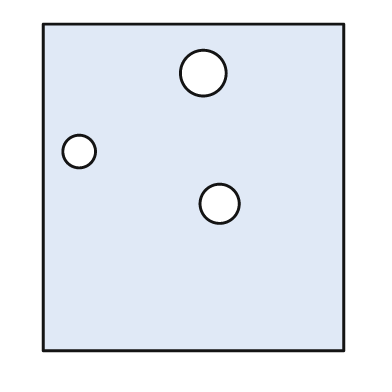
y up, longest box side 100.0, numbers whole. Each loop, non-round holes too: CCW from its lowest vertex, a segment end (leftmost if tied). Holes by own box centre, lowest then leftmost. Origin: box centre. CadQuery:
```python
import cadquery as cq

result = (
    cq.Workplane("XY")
    .moveTo(-46.0, -50.0)
    .lineTo(46.0, -50.0)
    .lineTo(46.0, 50.0)
    .lineTo(-46.0, 50.0)
    .close()
    .moveTo(8.0, -5.0)
    .circle(6.0)
    .moveTo(-35.0, 11.0)
    .circle(5.0)
    .moveTo(3.0, 35.0)
    .circle(7.0)
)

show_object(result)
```